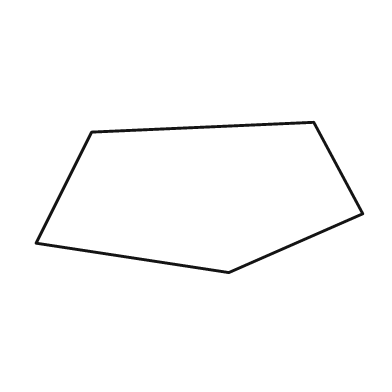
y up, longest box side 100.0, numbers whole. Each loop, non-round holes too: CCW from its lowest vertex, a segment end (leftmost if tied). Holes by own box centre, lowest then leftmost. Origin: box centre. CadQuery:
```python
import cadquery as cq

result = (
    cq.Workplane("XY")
    .moveTo(9.0, -23.0)
    .lineTo(50.0, -5.0)
    .lineTo(35.0, 23.0)
    .lineTo(-33.0, 20.0)
    .lineTo(-50.0, -14.0)
    .close()
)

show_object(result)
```